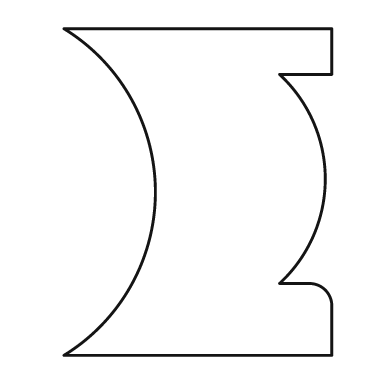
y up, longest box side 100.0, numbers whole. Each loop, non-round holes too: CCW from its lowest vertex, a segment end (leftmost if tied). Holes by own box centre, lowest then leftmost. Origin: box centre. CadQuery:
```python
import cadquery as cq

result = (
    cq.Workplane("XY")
    .moveTo(-41.0, -50.0)
    .lineTo(41.0, -50.0)
    .lineTo(41.0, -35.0)
    .threePointArc((39.0, -30.0), (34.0, -28.0))
    .lineTo(25.0, -28.0)
    .threePointArc((39.0, 4.0), (25.0, 36.0))
    .lineTo(41.0, 36.0)
    .lineTo(41.0, 50.0)
    .lineTo(-41.0, 50.0)
    .threePointArc((-13.0, 0.0), (-41.0, -50.0))
    .close()
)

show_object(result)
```